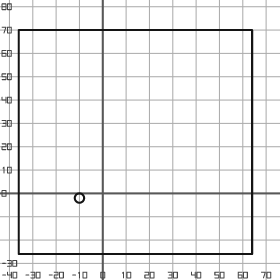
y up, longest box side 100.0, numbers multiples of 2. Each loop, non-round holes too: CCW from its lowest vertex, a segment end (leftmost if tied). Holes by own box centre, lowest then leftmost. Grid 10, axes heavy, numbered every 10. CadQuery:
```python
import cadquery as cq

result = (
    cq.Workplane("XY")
    .moveTo(-36.0, -26.0)
    .lineTo(64.0, -26.0)
    .lineTo(64.0, 70.0)
    .lineTo(-36.0, 70.0)
    .close()
    .moveTo(-10.0, -2.0)
    .circle(2.0)
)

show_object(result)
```